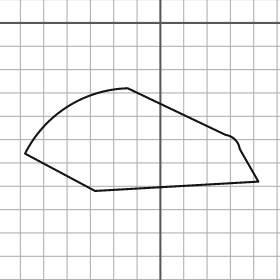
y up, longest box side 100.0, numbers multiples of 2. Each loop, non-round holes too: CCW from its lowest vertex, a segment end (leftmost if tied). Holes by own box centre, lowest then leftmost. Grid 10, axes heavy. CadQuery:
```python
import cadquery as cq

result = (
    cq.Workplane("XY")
    .moveTo(-28.0, -72.0)
    .lineTo(42.0, -68.0)
    .lineTo(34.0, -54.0)
    .threePointArc((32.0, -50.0), (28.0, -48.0))
    .lineTo(-14.0, -28.0)
    .threePointArc((-40.0, -36.0), (-58.0, -56.0))
    .close()
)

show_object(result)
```